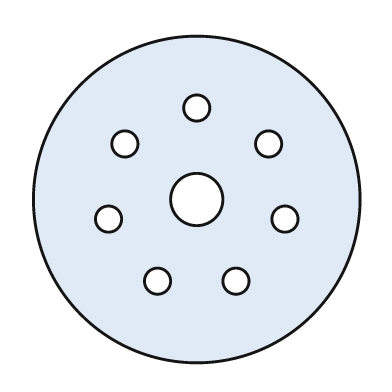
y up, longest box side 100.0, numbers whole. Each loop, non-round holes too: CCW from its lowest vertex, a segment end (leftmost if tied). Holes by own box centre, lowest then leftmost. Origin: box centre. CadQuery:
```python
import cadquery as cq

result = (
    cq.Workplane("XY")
    .moveTo(0.0, 0.0)
    .circle(50.0)
    .moveTo(-12.0, -25.0)
    .circle(4.0)
    .moveTo(12.0, -25.0)
    .circle(4.0)
    .moveTo(-27.0, -6.0)
    .circle(4.0)
    .moveTo(27.0, -6.0)
    .circle(4.0)
    .moveTo(0.0, 0.0)
    .circle(8.0)
    .moveTo(-22.0, 17.0)
    .circle(4.0)
    .moveTo(22.0, 17.0)
    .circle(4.0)
    .moveTo(0.0, 28.0)
    .circle(4.0)
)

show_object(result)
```